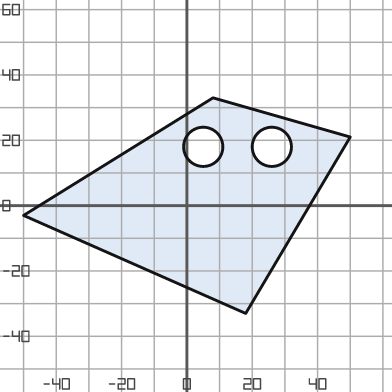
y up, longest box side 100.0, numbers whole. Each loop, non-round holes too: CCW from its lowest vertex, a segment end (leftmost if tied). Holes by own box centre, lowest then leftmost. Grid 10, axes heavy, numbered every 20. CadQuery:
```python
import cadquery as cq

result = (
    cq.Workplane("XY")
    .moveTo(18.0, -33.0)
    .lineTo(50.0, 21.0)
    .lineTo(8.0, 33.0)
    .lineTo(-50.0, -3.0)
    .close()
    .moveTo(5.0, 18.0)
    .circle(6.0)
    .moveTo(26.0, 18.0)
    .circle(6.0)
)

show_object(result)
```